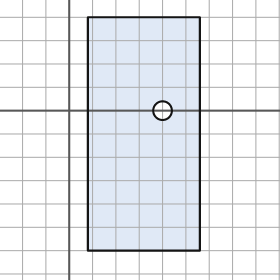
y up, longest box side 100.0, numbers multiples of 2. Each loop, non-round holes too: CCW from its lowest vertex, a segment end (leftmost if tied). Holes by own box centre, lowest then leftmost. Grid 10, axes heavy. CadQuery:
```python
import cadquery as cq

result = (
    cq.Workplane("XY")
    .moveTo(8.0, -60.0)
    .lineTo(56.0, -60.0)
    .lineTo(56.0, 40.0)
    .lineTo(8.0, 40.0)
    .close()
    .moveTo(40.0, 0.0)
    .circle(4.0)
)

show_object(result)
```